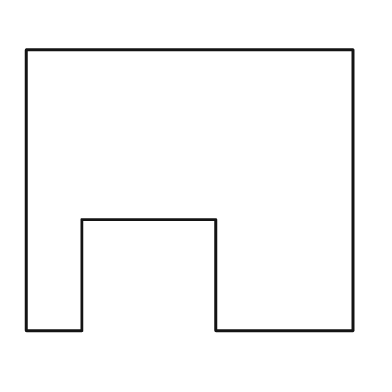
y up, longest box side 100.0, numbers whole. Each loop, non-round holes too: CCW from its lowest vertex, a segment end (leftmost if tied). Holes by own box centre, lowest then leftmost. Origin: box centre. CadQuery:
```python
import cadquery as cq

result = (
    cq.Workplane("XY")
    .moveTo(-50.0, -43.0)
    .lineTo(-33.0, -43.0)
    .lineTo(-33.0, -9.0)
    .lineTo(8.0, -9.0)
    .lineTo(8.0, -43.0)
    .lineTo(50.0, -43.0)
    .lineTo(50.0, 43.0)
    .lineTo(-50.0, 43.0)
    .close()
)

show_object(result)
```